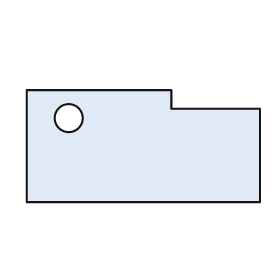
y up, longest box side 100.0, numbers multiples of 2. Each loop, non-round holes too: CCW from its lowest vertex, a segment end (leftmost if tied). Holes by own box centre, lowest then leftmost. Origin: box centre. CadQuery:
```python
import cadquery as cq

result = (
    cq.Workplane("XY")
    .moveTo(-50.0, -24.0)
    .lineTo(50.0, -24.0)
    .lineTo(50.0, 16.0)
    .lineTo(12.0, 16.0)
    .lineTo(12.0, 24.0)
    .lineTo(-50.0, 24.0)
    .close()
    .moveTo(-32.0, 12.0)
    .circle(6.0)
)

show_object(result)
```